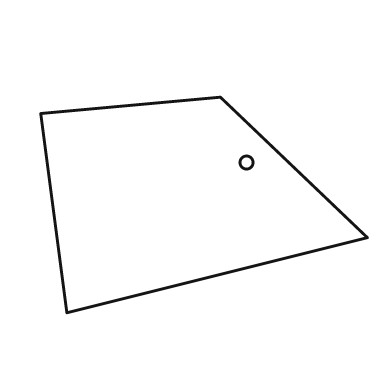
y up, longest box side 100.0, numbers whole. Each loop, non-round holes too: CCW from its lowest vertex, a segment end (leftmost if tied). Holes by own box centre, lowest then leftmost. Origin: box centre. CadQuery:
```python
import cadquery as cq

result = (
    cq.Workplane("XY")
    .moveTo(-42.0, -33.0)
    .lineTo(50.0, -10.0)
    .lineTo(5.0, 33.0)
    .lineTo(-50.0, 28.0)
    .close()
    .moveTo(13.0, 13.0)
    .circle(2.0)
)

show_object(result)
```